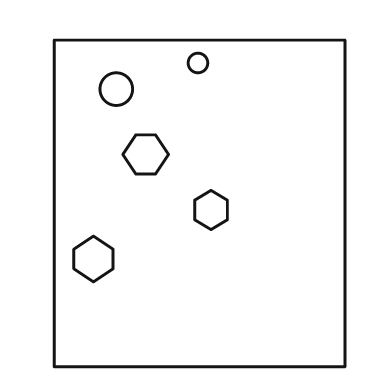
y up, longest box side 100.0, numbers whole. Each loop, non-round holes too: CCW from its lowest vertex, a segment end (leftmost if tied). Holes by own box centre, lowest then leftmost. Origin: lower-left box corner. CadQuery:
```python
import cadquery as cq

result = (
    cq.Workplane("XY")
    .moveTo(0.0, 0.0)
    .lineTo(89.0, 0.0)
    .lineTo(89.0, 100.0)
    .lineTo(0.0, 100.0)
    .close()
    .moveTo(12.0, 26.0)
    .lineTo(18.0, 30.0)
    .lineTo(18.0, 36.0)
    .lineTo(12.0, 40.0)
    .lineTo(6.0, 36.0)
    .lineTo(6.0, 30.0)
    .close()
    .moveTo(48.0, 42.0)
    .lineTo(53.0, 45.0)
    .lineTo(53.0, 51.0)
    .lineTo(48.0, 54.0)
    .lineTo(43.0, 51.0)
    .lineTo(43.0, 45.0)
    .close()
    .moveTo(25.0, 59.0)
    .lineTo(31.0, 59.0)
    .lineTo(35.0, 65.0)
    .lineTo(31.0, 71.0)
    .lineTo(25.0, 71.0)
    .lineTo(21.0, 65.0)
    .close()
    .moveTo(19.0, 85.0)
    .circle(5.0)
    .moveTo(44.0, 93.0)
    .circle(3.0)
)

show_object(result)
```